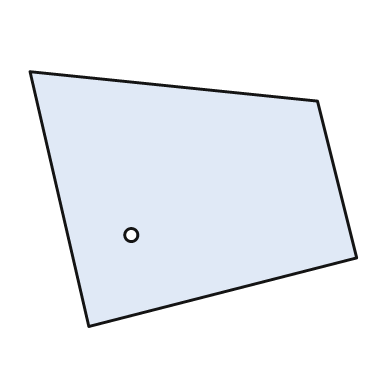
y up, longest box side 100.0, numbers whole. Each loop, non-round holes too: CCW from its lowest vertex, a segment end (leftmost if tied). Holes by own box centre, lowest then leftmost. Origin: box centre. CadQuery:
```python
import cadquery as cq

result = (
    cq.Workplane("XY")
    .moveTo(-32.0, -39.0)
    .lineTo(50.0, -18.0)
    .lineTo(38.0, 30.0)
    .lineTo(-50.0, 39.0)
    .close()
    .moveTo(-19.0, -11.0)
    .circle(2.0)
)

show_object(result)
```